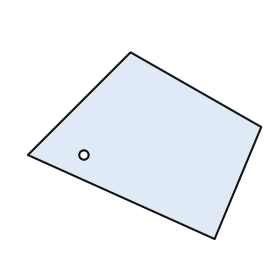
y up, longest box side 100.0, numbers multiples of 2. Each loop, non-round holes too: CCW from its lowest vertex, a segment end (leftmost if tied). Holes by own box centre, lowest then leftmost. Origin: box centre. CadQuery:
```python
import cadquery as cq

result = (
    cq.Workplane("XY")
    .moveTo(30.0, -40.0)
    .lineTo(50.0, 8.0)
    .lineTo(-6.0, 40.0)
    .lineTo(-50.0, -4.0)
    .close()
    .moveTo(-26.0, -4.0)
    .circle(2.0)
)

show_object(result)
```